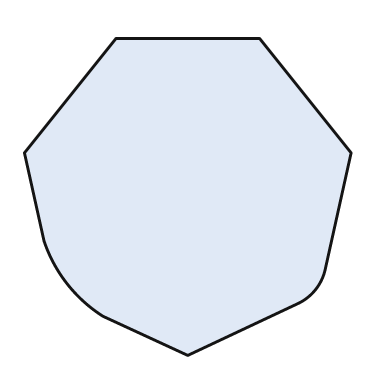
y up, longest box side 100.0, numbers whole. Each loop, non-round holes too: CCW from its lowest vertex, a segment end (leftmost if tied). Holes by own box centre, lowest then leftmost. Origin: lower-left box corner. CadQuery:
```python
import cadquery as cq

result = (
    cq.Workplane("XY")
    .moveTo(50.0, 0.0)
    .lineTo(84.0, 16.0)
    .threePointArc((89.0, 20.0), (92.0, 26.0))
    .lineTo(100.0, 62.0)
    .lineTo(72.0, 97.0)
    .lineTo(28.0, 97.0)
    .lineTo(0.0, 62.0)
    .lineTo(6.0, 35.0)
    .threePointArc((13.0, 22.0), (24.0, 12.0))
    .close()
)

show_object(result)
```